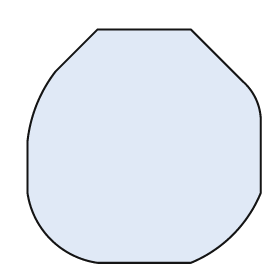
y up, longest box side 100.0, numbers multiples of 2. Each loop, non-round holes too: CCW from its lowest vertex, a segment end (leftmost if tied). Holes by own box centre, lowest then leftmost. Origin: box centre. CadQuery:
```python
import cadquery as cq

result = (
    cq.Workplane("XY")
    .moveTo(-20.0, -50.0)
    .lineTo(20.0, -50.0)
    .threePointArc((38.0, -38.0), (50.0, -20.0))
    .lineTo(50.0, 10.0)
    .threePointArc((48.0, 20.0), (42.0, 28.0))
    .lineTo(20.0, 50.0)
    .lineTo(-20.0, 50.0)
    .lineTo(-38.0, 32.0)
    .threePointArc((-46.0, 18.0), (-50.0, 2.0))
    .lineTo(-50.0, -20.0)
    .threePointArc((-40.0, -40.0), (-20.0, -50.0))
    .close()
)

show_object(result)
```